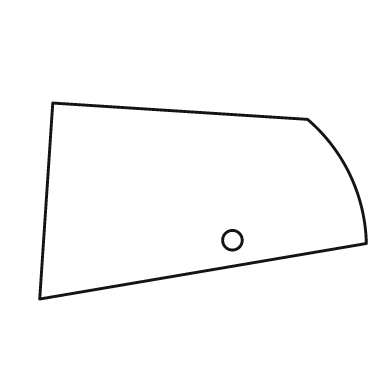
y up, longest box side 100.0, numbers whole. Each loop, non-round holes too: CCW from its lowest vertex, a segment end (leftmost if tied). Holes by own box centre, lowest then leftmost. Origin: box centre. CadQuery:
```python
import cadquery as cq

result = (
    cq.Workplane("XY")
    .moveTo(-50.0, -30.0)
    .lineTo(50.0, -13.0)
    .threePointArc((45.0, 8.0), (32.0, 25.0))
    .lineTo(-46.0, 30.0)
    .close()
    .moveTo(9.0, -12.0)
    .circle(3.0)
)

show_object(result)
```